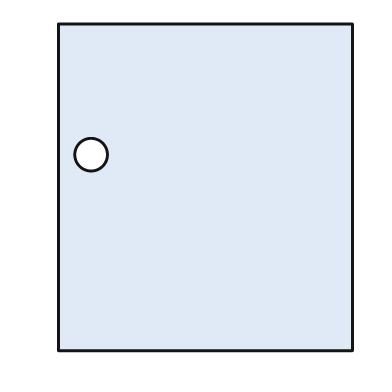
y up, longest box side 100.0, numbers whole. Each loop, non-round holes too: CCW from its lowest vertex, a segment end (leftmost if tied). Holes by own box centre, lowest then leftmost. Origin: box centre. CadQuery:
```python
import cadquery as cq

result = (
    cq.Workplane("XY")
    .moveTo(-45.0, -50.0)
    .lineTo(45.0, -50.0)
    .lineTo(45.0, 50.0)
    .lineTo(-45.0, 50.0)
    .close()
    .moveTo(-35.0, 10.0)
    .circle(5.0)
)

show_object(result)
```